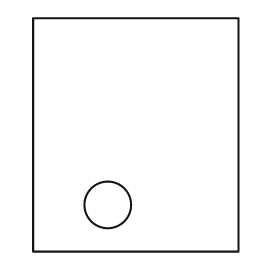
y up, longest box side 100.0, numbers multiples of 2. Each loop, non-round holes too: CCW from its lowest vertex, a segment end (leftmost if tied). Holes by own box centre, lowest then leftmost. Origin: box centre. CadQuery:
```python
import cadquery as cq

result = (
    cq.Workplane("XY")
    .moveTo(-44.0, -50.0)
    .lineTo(44.0, -50.0)
    .lineTo(44.0, 50.0)
    .lineTo(-44.0, 50.0)
    .close()
    .moveTo(-12.0, -30.0)
    .circle(10.0)
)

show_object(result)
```